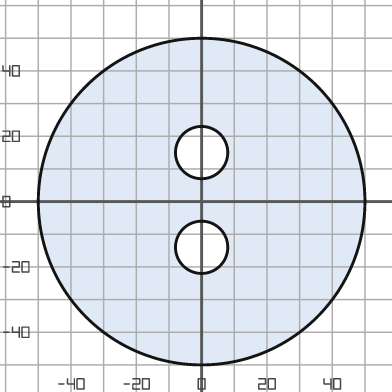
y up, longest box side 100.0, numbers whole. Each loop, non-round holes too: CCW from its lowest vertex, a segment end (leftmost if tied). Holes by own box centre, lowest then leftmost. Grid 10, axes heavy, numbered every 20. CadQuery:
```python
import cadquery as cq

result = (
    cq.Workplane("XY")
    .moveTo(0.0, 0.0)
    .circle(50.0)
    .moveTo(0.0, -14.0)
    .circle(8.0)
    .moveTo(0.0, 15.0)
    .circle(8.0)
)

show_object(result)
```